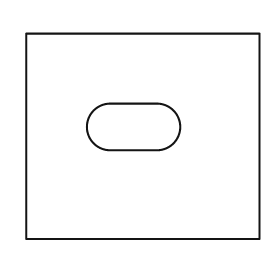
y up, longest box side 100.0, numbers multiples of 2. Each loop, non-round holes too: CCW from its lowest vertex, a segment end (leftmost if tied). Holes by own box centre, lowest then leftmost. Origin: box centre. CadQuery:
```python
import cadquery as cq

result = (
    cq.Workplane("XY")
    .moveTo(-50.0, -44.0)
    .lineTo(50.0, -44.0)
    .lineTo(50.0, 44.0)
    .lineTo(-50.0, 44.0)
    .close()
    .moveTo(-14.0, -6.0)
    .lineTo(6.0, -6.0)
    .threePointArc((16.0, 4.0), (6.0, 14.0))
    .lineTo(-14.0, 14.0)
    .threePointArc((-24.0, 4.0), (-14.0, -6.0))
    .close()
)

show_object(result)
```